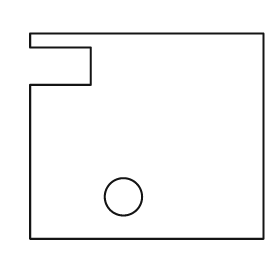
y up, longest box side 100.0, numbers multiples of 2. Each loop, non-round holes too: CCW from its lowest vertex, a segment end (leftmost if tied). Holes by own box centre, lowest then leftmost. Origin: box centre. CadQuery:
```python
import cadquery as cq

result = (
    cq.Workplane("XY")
    .moveTo(-50.0, -44.0)
    .lineTo(50.0, -44.0)
    .lineTo(50.0, 44.0)
    .lineTo(-50.0, 44.0)
    .lineTo(-50.0, 38.0)
    .lineTo(-24.0, 38.0)
    .lineTo(-24.0, 22.0)
    .lineTo(-50.0, 22.0)
    .close()
    .moveTo(-10.0, -26.0)
    .circle(8.0)
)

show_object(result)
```